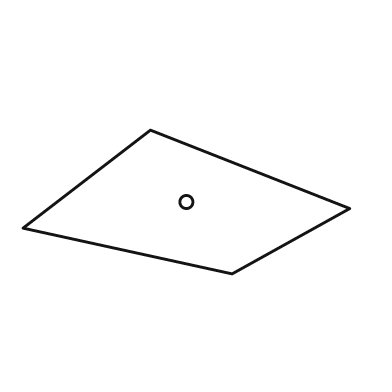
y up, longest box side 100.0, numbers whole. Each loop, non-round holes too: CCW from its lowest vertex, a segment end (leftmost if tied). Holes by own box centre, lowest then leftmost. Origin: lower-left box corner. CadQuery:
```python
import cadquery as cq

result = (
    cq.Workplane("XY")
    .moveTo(64.0, 0.0)
    .lineTo(100.0, 20.0)
    .lineTo(39.0, 44.0)
    .lineTo(0.0, 14.0)
    .close()
    .moveTo(50.0, 22.0)
    .circle(2.0)
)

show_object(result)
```